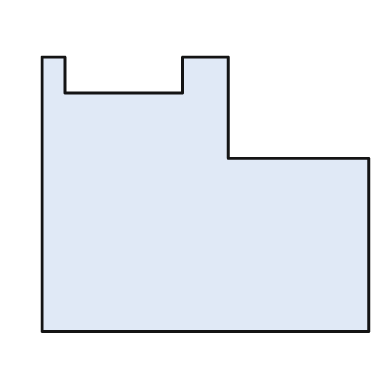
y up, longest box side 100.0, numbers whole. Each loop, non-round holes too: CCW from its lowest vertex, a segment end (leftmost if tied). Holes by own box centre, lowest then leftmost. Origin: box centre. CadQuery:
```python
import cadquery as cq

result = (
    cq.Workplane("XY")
    .moveTo(-50.0, -42.0)
    .lineTo(50.0, -42.0)
    .lineTo(50.0, 11.0)
    .lineTo(7.0, 11.0)
    .lineTo(7.0, 42.0)
    .lineTo(-7.0, 42.0)
    .lineTo(-7.0, 31.0)
    .lineTo(-43.0, 31.0)
    .lineTo(-43.0, 42.0)
    .lineTo(-50.0, 42.0)
    .close()
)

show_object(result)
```